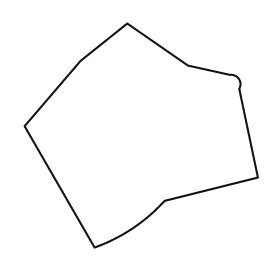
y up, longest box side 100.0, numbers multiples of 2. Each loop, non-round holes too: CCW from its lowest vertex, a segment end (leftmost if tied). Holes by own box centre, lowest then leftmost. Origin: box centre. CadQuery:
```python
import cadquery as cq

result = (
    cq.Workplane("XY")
    .moveTo(-20.0, -48.0)
    .threePointArc((-4.0, -40.0), (10.0, -28.0))
    .lineTo(50.0, -18.0)
    .lineTo(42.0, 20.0)
    .threePointArc((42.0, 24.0), (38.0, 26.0))
    .lineTo(20.0, 30.0)
    .lineTo(-6.0, 48.0)
    .lineTo(-26.0, 32.0)
    .lineTo(-50.0, 4.0)
    .close()
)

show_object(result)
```